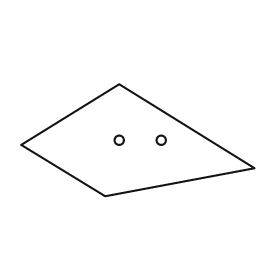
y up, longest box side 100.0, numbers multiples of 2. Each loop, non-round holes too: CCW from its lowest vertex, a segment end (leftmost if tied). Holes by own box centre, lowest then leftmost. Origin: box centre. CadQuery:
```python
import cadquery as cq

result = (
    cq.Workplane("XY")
    .moveTo(-14.0, -24.0)
    .lineTo(50.0, -12.0)
    .lineTo(-8.0, 24.0)
    .lineTo(-50.0, -2.0)
    .close()
    .moveTo(-8.0, 0.0)
    .circle(2.0)
    .moveTo(10.0, 0.0)
    .circle(2.0)
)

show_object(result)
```